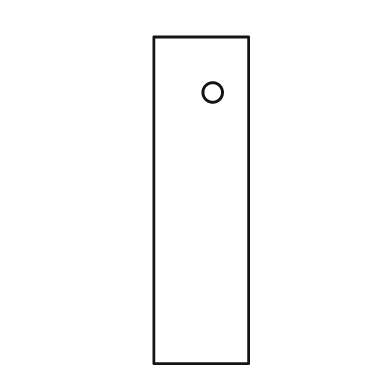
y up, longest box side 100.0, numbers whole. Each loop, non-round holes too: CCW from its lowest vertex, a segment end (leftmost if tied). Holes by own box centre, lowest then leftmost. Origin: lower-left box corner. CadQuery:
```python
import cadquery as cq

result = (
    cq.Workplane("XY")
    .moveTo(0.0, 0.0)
    .lineTo(29.0, 0.0)
    .lineTo(29.0, 100.0)
    .lineTo(0.0, 100.0)
    .close()
    .moveTo(18.0, 83.0)
    .circle(3.0)
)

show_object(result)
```